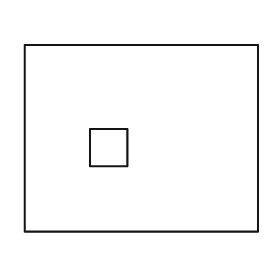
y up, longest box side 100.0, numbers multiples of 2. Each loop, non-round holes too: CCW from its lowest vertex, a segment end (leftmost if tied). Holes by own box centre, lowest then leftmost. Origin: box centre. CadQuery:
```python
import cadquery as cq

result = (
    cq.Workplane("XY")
    .moveTo(-50.0, -40.0)
    .lineTo(50.0, -40.0)
    .lineTo(50.0, 40.0)
    .lineTo(-50.0, 40.0)
    .close()
    .moveTo(-22.0, -12.0)
    .lineTo(-6.0, -12.0)
    .lineTo(-6.0, 4.0)
    .lineTo(-22.0, 4.0)
    .close()
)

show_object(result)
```